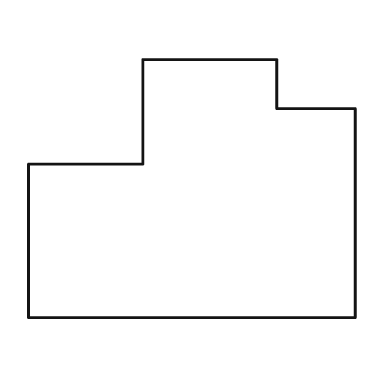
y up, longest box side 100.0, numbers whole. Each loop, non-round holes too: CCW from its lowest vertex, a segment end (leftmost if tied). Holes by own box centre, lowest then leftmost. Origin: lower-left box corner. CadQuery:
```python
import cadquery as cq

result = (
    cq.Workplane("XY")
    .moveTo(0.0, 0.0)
    .lineTo(100.0, 0.0)
    .lineTo(100.0, 64.0)
    .lineTo(76.0, 64.0)
    .lineTo(76.0, 79.0)
    .lineTo(35.0, 79.0)
    .lineTo(35.0, 47.0)
    .lineTo(0.0, 47.0)
    .close()
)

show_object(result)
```